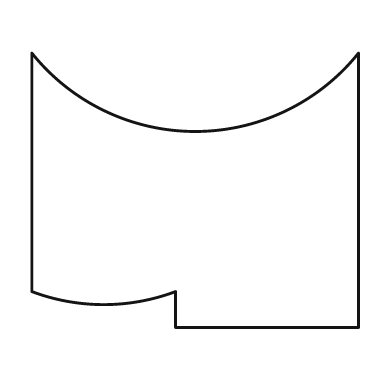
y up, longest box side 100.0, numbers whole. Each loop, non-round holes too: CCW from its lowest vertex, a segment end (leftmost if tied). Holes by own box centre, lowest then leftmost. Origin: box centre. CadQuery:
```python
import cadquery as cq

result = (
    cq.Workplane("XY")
    .moveTo(-6.0, -42.0)
    .lineTo(50.0, -42.0)
    .lineTo(50.0, 42.0)
    .threePointArc((0.0, 18.0), (-50.0, 42.0))
    .lineTo(-50.0, -31.0)
    .threePointArc((-28.0, -35.0), (-6.0, -31.0))
    .close()
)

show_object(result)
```